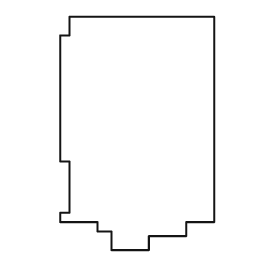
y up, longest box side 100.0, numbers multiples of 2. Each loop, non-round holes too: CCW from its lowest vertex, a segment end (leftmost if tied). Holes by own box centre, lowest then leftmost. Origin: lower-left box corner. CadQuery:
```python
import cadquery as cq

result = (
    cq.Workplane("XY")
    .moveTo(22.0, 0.0)
    .lineTo(38.0, 0.0)
    .lineTo(38.0, 6.0)
    .lineTo(54.0, 6.0)
    .lineTo(54.0, 12.0)
    .lineTo(66.0, 12.0)
    .lineTo(66.0, 100.0)
    .lineTo(4.0, 100.0)
    .lineTo(4.0, 92.0)
    .lineTo(0.0, 92.0)
    .lineTo(0.0, 38.0)
    .lineTo(4.0, 38.0)
    .lineTo(4.0, 16.0)
    .lineTo(0.0, 16.0)
    .lineTo(0.0, 12.0)
    .lineTo(16.0, 12.0)
    .lineTo(16.0, 8.0)
    .lineTo(22.0, 8.0)
    .close()
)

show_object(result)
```